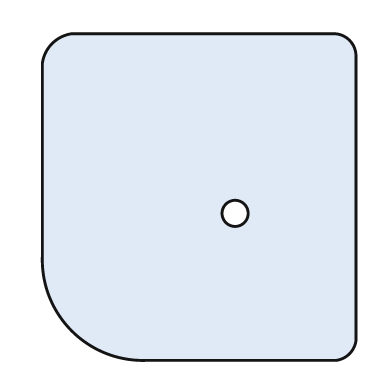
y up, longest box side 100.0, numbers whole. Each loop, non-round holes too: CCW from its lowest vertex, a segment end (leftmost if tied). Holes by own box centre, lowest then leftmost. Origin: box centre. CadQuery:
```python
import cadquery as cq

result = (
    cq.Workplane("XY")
    .moveTo(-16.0, -50.0)
    .lineTo(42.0, -50.0)
    .threePointArc((46.0, -48.0), (48.0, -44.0))
    .lineTo(48.0, 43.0)
    .threePointArc((46.0, 48.0), (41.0, 50.0))
    .lineTo(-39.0, 50.0)
    .threePointArc((-45.0, 47.0), (-48.0, 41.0))
    .lineTo(-48.0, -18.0)
    .threePointArc((-39.0, -41.0), (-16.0, -50.0))
    .close()
    .moveTo(11.0, -5.0)
    .circle(4.0)
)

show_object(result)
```